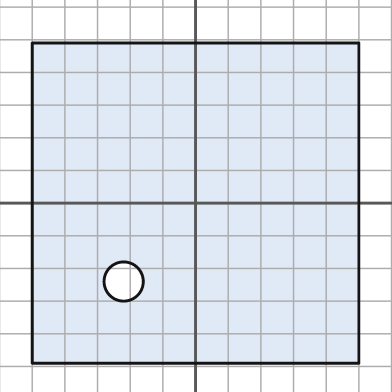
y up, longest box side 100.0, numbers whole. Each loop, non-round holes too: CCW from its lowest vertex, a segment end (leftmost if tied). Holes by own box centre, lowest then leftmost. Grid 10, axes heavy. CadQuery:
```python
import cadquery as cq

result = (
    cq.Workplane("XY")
    .moveTo(-50.0, -49.0)
    .lineTo(50.0, -49.0)
    .lineTo(50.0, 49.0)
    .lineTo(-50.0, 49.0)
    .close()
    .moveTo(-22.0, -24.0)
    .circle(6.0)
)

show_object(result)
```